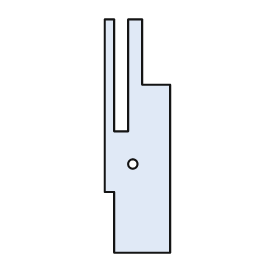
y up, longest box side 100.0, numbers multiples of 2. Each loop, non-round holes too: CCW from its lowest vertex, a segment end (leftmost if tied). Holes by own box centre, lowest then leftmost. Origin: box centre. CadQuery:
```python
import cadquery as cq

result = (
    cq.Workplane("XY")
    .moveTo(-10.0, -50.0)
    .lineTo(14.0, -50.0)
    .lineTo(14.0, 22.0)
    .lineTo(2.0, 22.0)
    .lineTo(2.0, 50.0)
    .lineTo(-4.0, 50.0)
    .lineTo(-4.0, 2.0)
    .lineTo(-10.0, 2.0)
    .lineTo(-10.0, 50.0)
    .lineTo(-14.0, 50.0)
    .lineTo(-14.0, -24.0)
    .lineTo(-10.0, -24.0)
    .close()
    .moveTo(-2.0, -12.0)
    .circle(2.0)
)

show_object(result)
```